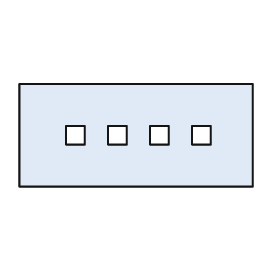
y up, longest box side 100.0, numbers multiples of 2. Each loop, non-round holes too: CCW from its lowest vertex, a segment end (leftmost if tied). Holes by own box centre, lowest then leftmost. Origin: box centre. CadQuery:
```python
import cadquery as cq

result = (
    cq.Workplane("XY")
    .moveTo(-50.0, -22.0)
    .lineTo(50.0, -22.0)
    .lineTo(50.0, 22.0)
    .lineTo(-50.0, 22.0)
    .close()
    .moveTo(-30.0, -4.0)
    .lineTo(-22.0, -4.0)
    .lineTo(-22.0, 4.0)
    .lineTo(-30.0, 4.0)
    .close()
    .moveTo(-12.0, -4.0)
    .lineTo(-4.0, -4.0)
    .lineTo(-4.0, 4.0)
    .lineTo(-12.0, 4.0)
    .close()
    .moveTo(6.0, -4.0)
    .lineTo(14.0, -4.0)
    .lineTo(14.0, 4.0)
    .lineTo(6.0, 4.0)
    .close()
    .moveTo(24.0, -4.0)
    .lineTo(32.0, -4.0)
    .lineTo(32.0, 4.0)
    .lineTo(24.0, 4.0)
    .close()
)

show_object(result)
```